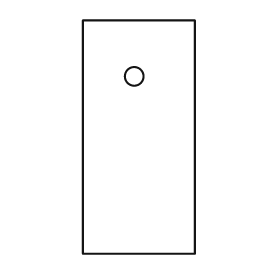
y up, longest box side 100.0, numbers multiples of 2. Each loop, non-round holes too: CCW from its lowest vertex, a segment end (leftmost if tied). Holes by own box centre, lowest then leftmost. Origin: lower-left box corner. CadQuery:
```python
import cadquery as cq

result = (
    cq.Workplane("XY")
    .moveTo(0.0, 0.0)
    .lineTo(48.0, 0.0)
    .lineTo(48.0, 100.0)
    .lineTo(0.0, 100.0)
    .close()
    .moveTo(22.0, 76.0)
    .circle(4.0)
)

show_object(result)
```